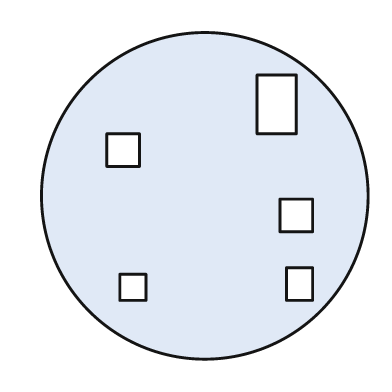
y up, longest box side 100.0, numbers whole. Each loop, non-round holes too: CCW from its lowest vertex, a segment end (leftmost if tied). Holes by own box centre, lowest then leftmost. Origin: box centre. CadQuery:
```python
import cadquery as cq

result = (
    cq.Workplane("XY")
    .moveTo(0.0, 0.0)
    .circle(50.0)
    .moveTo(-26.0, -32.0)
    .lineTo(-18.0, -32.0)
    .lineTo(-18.0, -24.0)
    .lineTo(-26.0, -24.0)
    .close()
    .moveTo(25.0, -32.0)
    .lineTo(33.0, -32.0)
    .lineTo(33.0, -22.0)
    .lineTo(25.0, -22.0)
    .close()
    .moveTo(23.0, -11.0)
    .lineTo(33.0, -11.0)
    .lineTo(33.0, -1.0)
    .lineTo(23.0, -1.0)
    .close()
    .moveTo(-30.0, 9.0)
    .lineTo(-20.0, 9.0)
    .lineTo(-20.0, 19.0)
    .lineTo(-30.0, 19.0)
    .close()
    .moveTo(16.0, 19.0)
    .lineTo(28.0, 19.0)
    .lineTo(28.0, 37.0)
    .lineTo(16.0, 37.0)
    .close()
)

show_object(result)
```